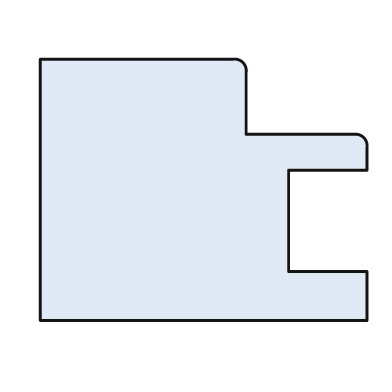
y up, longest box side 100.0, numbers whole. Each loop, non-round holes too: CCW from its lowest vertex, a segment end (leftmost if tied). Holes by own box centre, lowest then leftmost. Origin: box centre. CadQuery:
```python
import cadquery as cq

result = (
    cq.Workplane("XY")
    .moveTo(-50.0, -40.0)
    .lineTo(50.0, -40.0)
    .lineTo(50.0, -25.0)
    .lineTo(26.0, -25.0)
    .lineTo(26.0, 6.0)
    .lineTo(50.0, 6.0)
    .lineTo(50.0, 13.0)
    .threePointArc((49.0, 16.0), (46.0, 17.0))
    .lineTo(13.0, 17.0)
    .lineTo(13.0, 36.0)
    .threePointArc((12.0, 39.0), (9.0, 40.0))
    .lineTo(-50.0, 40.0)
    .close()
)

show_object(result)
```